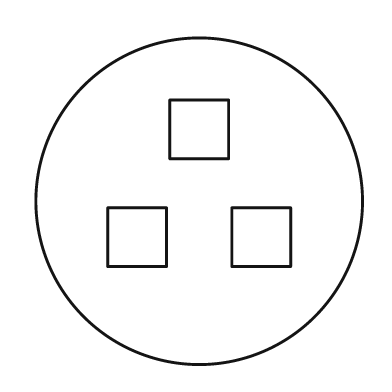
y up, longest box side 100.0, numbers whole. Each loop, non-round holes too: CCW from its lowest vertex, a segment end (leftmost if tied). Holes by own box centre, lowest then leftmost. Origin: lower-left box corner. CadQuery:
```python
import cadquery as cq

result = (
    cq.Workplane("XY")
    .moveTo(50.0, 50.0)
    .circle(50.0)
    .moveTo(22.0, 30.0)
    .lineTo(40.0, 30.0)
    .lineTo(40.0, 48.0)
    .lineTo(22.0, 48.0)
    .close()
    .moveTo(60.0, 30.0)
    .lineTo(78.0, 30.0)
    .lineTo(78.0, 48.0)
    .lineTo(60.0, 48.0)
    .close()
    .moveTo(41.0, 63.0)
    .lineTo(59.0, 63.0)
    .lineTo(59.0, 81.0)
    .lineTo(41.0, 81.0)
    .close()
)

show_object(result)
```